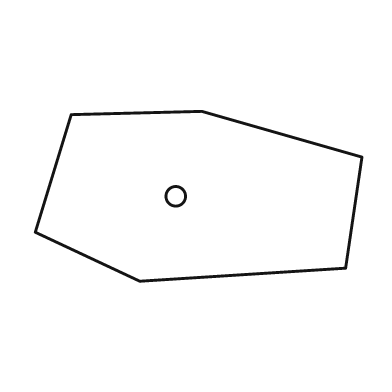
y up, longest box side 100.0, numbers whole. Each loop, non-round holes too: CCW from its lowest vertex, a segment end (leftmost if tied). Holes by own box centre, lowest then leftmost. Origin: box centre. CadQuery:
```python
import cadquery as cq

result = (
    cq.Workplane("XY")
    .moveTo(-18.0, -26.0)
    .lineTo(45.0, -22.0)
    .lineTo(50.0, 12.0)
    .lineTo(1.0, 26.0)
    .lineTo(-39.0, 25.0)
    .lineTo(-50.0, -11.0)
    .close()
    .moveTo(-7.0, 0.0)
    .circle(3.0)
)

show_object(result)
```